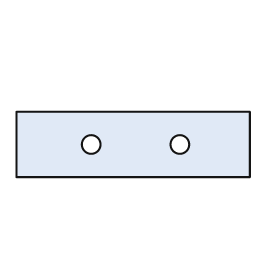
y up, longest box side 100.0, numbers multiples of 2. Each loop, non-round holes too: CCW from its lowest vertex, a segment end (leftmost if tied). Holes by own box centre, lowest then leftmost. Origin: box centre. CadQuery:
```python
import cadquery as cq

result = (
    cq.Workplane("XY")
    .moveTo(-50.0, -14.0)
    .lineTo(50.0, -14.0)
    .lineTo(50.0, 14.0)
    .lineTo(-50.0, 14.0)
    .close()
    .moveTo(-18.0, 0.0)
    .circle(4.0)
    .moveTo(20.0, 0.0)
    .circle(4.0)
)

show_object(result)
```